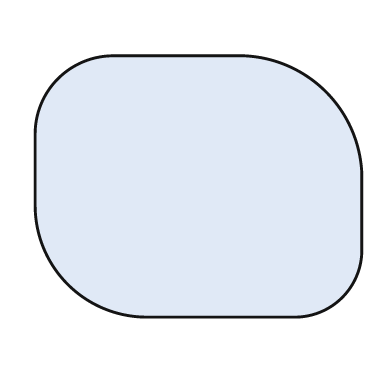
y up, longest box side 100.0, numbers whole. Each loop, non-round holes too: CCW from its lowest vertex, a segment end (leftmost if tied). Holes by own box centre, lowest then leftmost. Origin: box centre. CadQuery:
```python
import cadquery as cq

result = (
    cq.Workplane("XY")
    .moveTo(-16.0, -40.0)
    .lineTo(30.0, -40.0)
    .threePointArc((44.0, -34.0), (50.0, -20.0))
    .lineTo(50.0, 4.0)
    .threePointArc((39.0, 29.0), (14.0, 40.0))
    .lineTo(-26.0, 40.0)
    .threePointArc((-43.0, 33.0), (-50.0, 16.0))
    .lineTo(-50.0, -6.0)
    .threePointArc((-40.0, -30.0), (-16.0, -40.0))
    .close()
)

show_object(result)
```